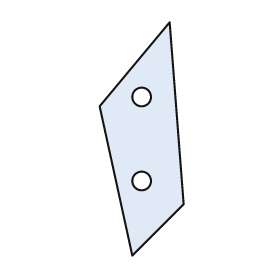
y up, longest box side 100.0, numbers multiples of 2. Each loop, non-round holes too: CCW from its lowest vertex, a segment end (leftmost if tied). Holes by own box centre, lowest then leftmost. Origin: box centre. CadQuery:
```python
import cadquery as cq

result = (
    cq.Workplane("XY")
    .moveTo(-4.0, -50.0)
    .lineTo(18.0, -28.0)
    .lineTo(12.0, 50.0)
    .lineTo(-18.0, 14.0)
    .close()
    .moveTo(0.0, -18.0)
    .circle(4.0)
    .moveTo(0.0, 18.0)
    .circle(4.0)
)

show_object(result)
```